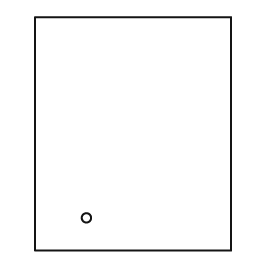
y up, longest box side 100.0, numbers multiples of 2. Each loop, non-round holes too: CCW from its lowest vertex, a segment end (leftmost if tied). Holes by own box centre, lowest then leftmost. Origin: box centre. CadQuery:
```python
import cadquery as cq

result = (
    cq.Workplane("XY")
    .moveTo(-42.0, -50.0)
    .lineTo(42.0, -50.0)
    .lineTo(42.0, 50.0)
    .lineTo(-42.0, 50.0)
    .close()
    .moveTo(-20.0, -36.0)
    .circle(2.0)
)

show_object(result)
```